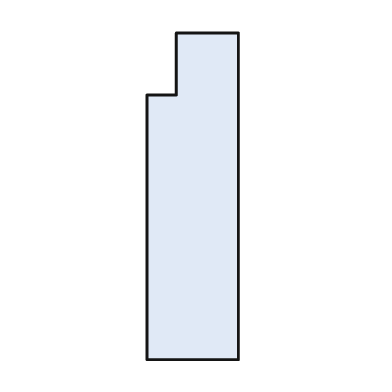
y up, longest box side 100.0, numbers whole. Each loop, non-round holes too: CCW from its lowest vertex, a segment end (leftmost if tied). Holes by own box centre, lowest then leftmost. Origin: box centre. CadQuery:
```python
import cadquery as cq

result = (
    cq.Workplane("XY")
    .moveTo(-14.0, -50.0)
    .lineTo(14.0, -50.0)
    .lineTo(14.0, 50.0)
    .lineTo(-5.0, 50.0)
    .lineTo(-5.0, 31.0)
    .lineTo(-14.0, 31.0)
    .close()
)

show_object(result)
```